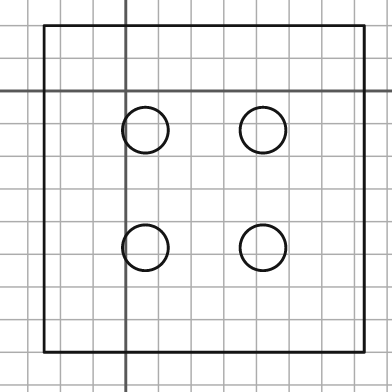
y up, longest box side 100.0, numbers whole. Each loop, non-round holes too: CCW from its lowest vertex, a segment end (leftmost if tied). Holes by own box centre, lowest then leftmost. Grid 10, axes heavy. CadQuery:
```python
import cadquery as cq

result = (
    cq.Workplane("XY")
    .moveTo(-25.0, -80.0)
    .lineTo(73.0, -80.0)
    .lineTo(73.0, 20.0)
    .lineTo(-25.0, 20.0)
    .close()
    .moveTo(6.0, -48.0)
    .circle(7.0)
    .moveTo(42.0, -48.0)
    .circle(7.0)
    .moveTo(6.0, -12.0)
    .circle(7.0)
    .moveTo(42.0, -12.0)
    .circle(7.0)
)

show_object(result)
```